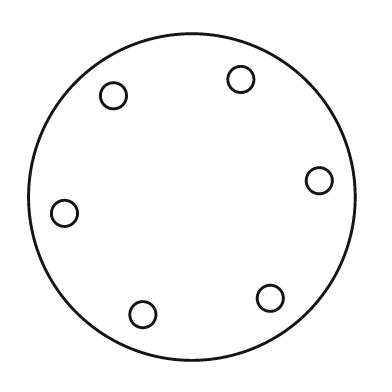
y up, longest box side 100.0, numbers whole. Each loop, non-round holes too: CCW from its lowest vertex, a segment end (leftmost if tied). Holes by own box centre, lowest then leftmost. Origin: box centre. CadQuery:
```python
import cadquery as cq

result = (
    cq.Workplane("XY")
    .moveTo(0.0, 0.0)
    .circle(50.0)
    .moveTo(-15.0, -36.0)
    .circle(4.0)
    .moveTo(24.0, -31.0)
    .circle(4.0)
    .moveTo(-39.0, -5.0)
    .circle(4.0)
    .moveTo(39.0, 5.0)
    .circle(4.0)
    .moveTo(-24.0, 31.0)
    .circle(4.0)
    .moveTo(15.0, 36.0)
    .circle(4.0)
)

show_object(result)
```